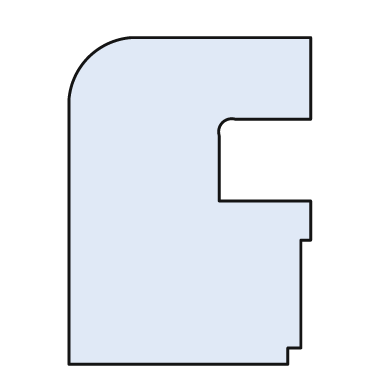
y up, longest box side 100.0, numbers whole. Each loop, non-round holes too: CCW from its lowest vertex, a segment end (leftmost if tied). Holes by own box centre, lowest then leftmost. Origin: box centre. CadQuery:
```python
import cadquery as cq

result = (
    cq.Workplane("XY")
    .moveTo(-37.0, -50.0)
    .lineTo(30.0, -50.0)
    .lineTo(30.0, -45.0)
    .lineTo(34.0, -45.0)
    .lineTo(34.0, -12.0)
    .lineTo(37.0, -12.0)
    .lineTo(37.0, 0.0)
    .lineTo(9.0, 0.0)
    .lineTo(9.0, 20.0)
    .threePointArc((10.0, 24.0), (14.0, 25.0))
    .lineTo(37.0, 25.0)
    .lineTo(37.0, 50.0)
    .lineTo(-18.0, 50.0)
    .threePointArc((-31.0, 44.0), (-37.0, 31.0))
    .close()
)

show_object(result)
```